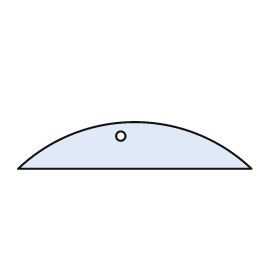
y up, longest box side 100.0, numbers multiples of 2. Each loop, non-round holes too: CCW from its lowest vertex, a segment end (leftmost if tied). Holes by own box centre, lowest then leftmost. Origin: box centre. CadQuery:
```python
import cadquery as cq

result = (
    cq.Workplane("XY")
    .moveTo(-50.0, -10.0)
    .lineTo(50.0, -10.0)
    .threePointArc((0.0, 10.0), (-50.0, -10.0))
    .close()
    .moveTo(-6.0, 4.0)
    .circle(2.0)
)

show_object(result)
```